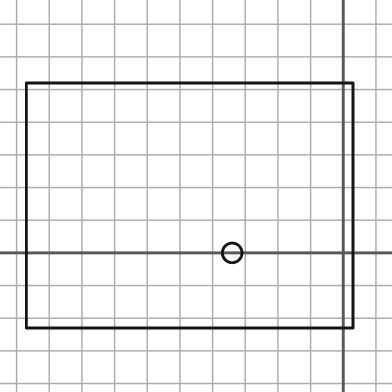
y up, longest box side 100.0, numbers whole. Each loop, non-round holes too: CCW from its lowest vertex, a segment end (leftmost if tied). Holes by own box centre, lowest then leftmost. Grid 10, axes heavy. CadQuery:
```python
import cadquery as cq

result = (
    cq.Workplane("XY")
    .moveTo(-97.0, -23.0)
    .lineTo(3.0, -23.0)
    .lineTo(3.0, 52.0)
    .lineTo(-97.0, 52.0)
    .close()
    .moveTo(-34.0, 0.0)
    .circle(3.0)
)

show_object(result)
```